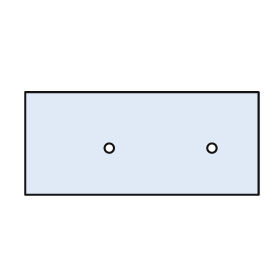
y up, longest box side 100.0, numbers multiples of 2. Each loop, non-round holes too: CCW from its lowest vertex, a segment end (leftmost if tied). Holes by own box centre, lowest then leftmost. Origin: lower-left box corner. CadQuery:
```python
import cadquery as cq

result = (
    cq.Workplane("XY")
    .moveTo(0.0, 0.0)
    .lineTo(100.0, 0.0)
    .lineTo(100.0, 44.0)
    .lineTo(0.0, 44.0)
    .close()
    .moveTo(36.0, 20.0)
    .circle(2.0)
    .moveTo(80.0, 20.0)
    .circle(2.0)
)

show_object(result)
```